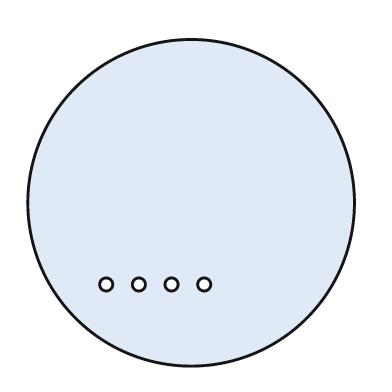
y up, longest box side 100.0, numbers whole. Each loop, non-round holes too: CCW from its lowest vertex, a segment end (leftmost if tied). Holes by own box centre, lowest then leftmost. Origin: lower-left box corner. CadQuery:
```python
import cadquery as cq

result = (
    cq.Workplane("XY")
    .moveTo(50.0, 50.0)
    .circle(50.0)
    .moveTo(24.0, 25.0)
    .circle(2.0)
    .moveTo(34.0, 25.0)
    .circle(2.0)
    .moveTo(44.0, 25.0)
    .circle(2.0)
    .moveTo(54.0, 25.0)
    .circle(2.0)
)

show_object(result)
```